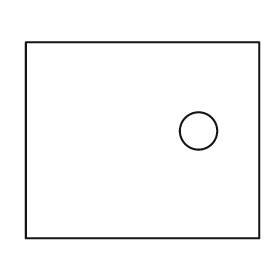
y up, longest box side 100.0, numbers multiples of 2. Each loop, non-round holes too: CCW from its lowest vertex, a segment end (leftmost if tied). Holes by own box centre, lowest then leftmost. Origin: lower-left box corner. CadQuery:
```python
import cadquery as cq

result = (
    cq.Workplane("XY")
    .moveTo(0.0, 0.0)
    .lineTo(100.0, 0.0)
    .lineTo(100.0, 84.0)
    .lineTo(0.0, 84.0)
    .close()
    .moveTo(74.0, 46.0)
    .circle(8.0)
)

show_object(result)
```